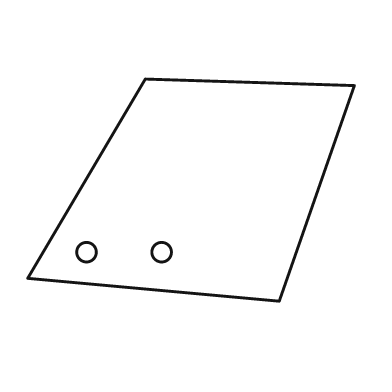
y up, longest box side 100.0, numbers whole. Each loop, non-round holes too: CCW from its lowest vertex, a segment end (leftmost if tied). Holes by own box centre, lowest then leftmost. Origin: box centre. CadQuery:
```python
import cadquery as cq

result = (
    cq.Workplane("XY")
    .moveTo(27.0, -34.0)
    .lineTo(50.0, 32.0)
    .lineTo(-14.0, 34.0)
    .lineTo(-50.0, -27.0)
    .close()
    .moveTo(-32.0, -19.0)
    .circle(3.0)
    .moveTo(-9.0, -19.0)
    .circle(3.0)
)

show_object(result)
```